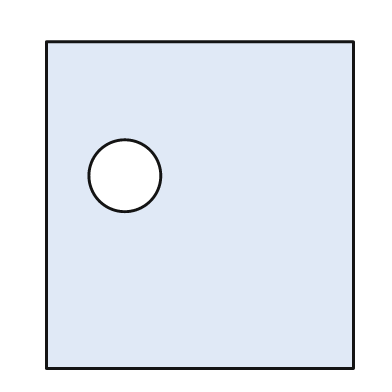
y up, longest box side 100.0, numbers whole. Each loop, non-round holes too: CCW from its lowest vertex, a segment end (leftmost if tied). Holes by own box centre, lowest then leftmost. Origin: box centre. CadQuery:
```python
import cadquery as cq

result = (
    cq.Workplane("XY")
    .moveTo(-47.0, -50.0)
    .lineTo(47.0, -50.0)
    .lineTo(47.0, 50.0)
    .lineTo(-47.0, 50.0)
    .close()
    .moveTo(-23.0, 9.0)
    .circle(11.0)
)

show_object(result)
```